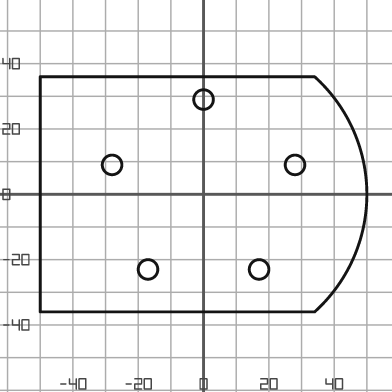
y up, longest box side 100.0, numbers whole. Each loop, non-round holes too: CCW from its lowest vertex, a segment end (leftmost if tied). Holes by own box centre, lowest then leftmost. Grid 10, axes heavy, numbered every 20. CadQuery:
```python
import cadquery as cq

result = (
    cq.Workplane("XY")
    .moveTo(-50.0, -36.0)
    .lineTo(34.0, -36.0)
    .threePointArc((50.0, 0.0), (34.0, 36.0))
    .lineTo(-50.0, 36.0)
    .close()
    .moveTo(-17.0, -23.0)
    .circle(3.0)
    .moveTo(17.0, -23.0)
    .circle(3.0)
    .moveTo(-28.0, 9.0)
    .circle(3.0)
    .moveTo(28.0, 9.0)
    .circle(3.0)
    .moveTo(0.0, 29.0)
    .circle(3.0)
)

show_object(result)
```